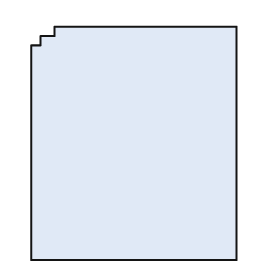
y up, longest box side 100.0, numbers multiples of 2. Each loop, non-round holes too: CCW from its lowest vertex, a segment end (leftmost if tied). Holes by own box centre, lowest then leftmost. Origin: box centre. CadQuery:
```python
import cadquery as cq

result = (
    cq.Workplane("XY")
    .moveTo(-44.0, -50.0)
    .lineTo(44.0, -50.0)
    .lineTo(44.0, 50.0)
    .lineTo(-34.0, 50.0)
    .lineTo(-34.0, 46.0)
    .lineTo(-40.0, 46.0)
    .lineTo(-40.0, 42.0)
    .lineTo(-44.0, 42.0)
    .close()
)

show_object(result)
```